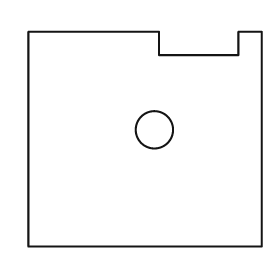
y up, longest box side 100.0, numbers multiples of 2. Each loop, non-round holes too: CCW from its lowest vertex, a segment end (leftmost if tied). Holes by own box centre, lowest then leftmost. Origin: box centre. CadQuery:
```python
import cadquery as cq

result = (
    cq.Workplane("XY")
    .moveTo(-50.0, -46.0)
    .lineTo(50.0, -46.0)
    .lineTo(50.0, 46.0)
    .lineTo(40.0, 46.0)
    .lineTo(40.0, 36.0)
    .lineTo(6.0, 36.0)
    .lineTo(6.0, 46.0)
    .lineTo(-50.0, 46.0)
    .close()
    .moveTo(4.0, 4.0)
    .circle(8.0)
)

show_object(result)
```